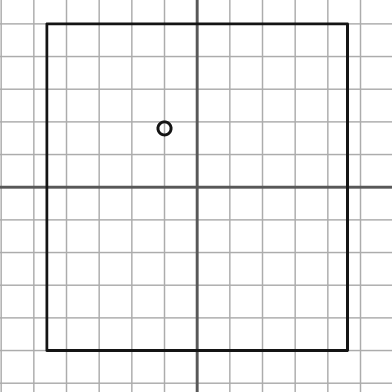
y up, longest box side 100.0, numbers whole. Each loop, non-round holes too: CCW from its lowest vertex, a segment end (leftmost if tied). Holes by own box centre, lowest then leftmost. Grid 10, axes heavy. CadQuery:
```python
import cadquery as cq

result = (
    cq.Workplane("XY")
    .moveTo(-46.0, -50.0)
    .lineTo(46.0, -50.0)
    .lineTo(46.0, 50.0)
    .lineTo(-46.0, 50.0)
    .close()
    .moveTo(-10.0, 18.0)
    .circle(2.0)
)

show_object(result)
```